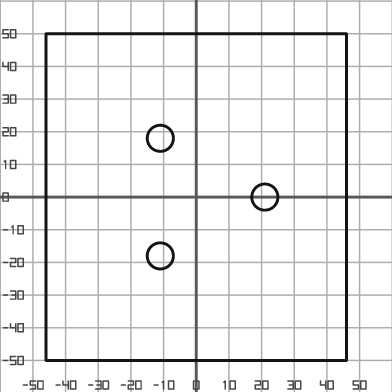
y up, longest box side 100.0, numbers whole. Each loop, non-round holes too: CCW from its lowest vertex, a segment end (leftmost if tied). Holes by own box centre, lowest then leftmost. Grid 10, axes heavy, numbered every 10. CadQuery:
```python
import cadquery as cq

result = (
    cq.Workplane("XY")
    .moveTo(-46.0, -50.0)
    .lineTo(46.0, -50.0)
    .lineTo(46.0, 50.0)
    .lineTo(-46.0, 50.0)
    .close()
    .moveTo(-11.0, -18.0)
    .circle(4.0)
    .moveTo(21.0, 0.0)
    .circle(4.0)
    .moveTo(-11.0, 18.0)
    .circle(4.0)
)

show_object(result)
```